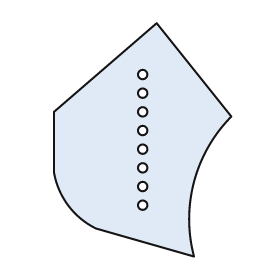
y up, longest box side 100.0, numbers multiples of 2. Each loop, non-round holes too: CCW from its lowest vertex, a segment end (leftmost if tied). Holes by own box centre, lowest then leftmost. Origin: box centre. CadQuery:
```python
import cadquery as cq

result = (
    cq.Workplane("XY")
    .moveTo(22.0, -50.0)
    .threePointArc((22.0, -18.0), (38.0, 10.0))
    .lineTo(6.0, 50.0)
    .lineTo(-38.0, 12.0)
    .lineTo(-38.0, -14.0)
    .threePointArc((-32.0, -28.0), (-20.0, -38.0))
    .close()
    .moveTo(0.0, -28.0)
    .circle(2.0)
    .moveTo(0.0, -20.0)
    .circle(2.0)
    .moveTo(0.0, -12.0)
    .circle(2.0)
    .moveTo(0.0, -4.0)
    .circle(2.0)
    .moveTo(0.0, 4.0)
    .circle(2.0)
    .moveTo(0.0, 12.0)
    .circle(2.0)
    .moveTo(0.0, 20.0)
    .circle(2.0)
    .moveTo(0.0, 28.0)
    .circle(2.0)
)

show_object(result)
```